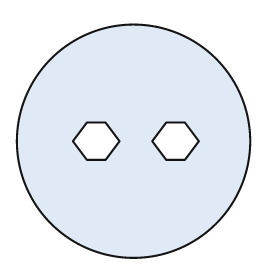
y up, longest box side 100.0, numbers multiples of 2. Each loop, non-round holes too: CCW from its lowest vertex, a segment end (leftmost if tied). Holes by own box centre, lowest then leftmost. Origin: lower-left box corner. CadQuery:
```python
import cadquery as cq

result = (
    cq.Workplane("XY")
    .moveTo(50.0, 50.0)
    .circle(50.0)
    .moveTo(30.0, 42.0)
    .lineTo(38.0, 42.0)
    .lineTo(44.0, 50.0)
    .lineTo(38.0, 58.0)
    .lineTo(30.0, 58.0)
    .lineTo(24.0, 50.0)
    .close()
    .moveTo(64.0, 42.0)
    .lineTo(72.0, 42.0)
    .lineTo(78.0, 50.0)
    .lineTo(72.0, 58.0)
    .lineTo(64.0, 58.0)
    .lineTo(58.0, 50.0)
    .close()
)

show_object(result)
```